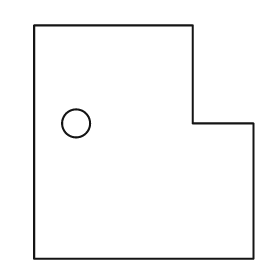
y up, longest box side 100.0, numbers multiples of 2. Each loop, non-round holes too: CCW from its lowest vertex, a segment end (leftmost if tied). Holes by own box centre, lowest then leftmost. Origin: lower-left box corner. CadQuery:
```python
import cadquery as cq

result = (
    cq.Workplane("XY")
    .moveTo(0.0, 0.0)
    .lineTo(94.0, 0.0)
    .lineTo(94.0, 58.0)
    .lineTo(68.0, 58.0)
    .lineTo(68.0, 100.0)
    .lineTo(0.0, 100.0)
    .close()
    .moveTo(18.0, 58.0)
    .circle(6.0)
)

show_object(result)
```